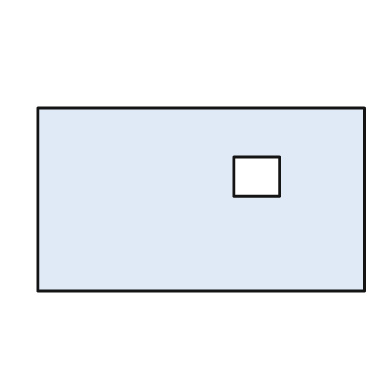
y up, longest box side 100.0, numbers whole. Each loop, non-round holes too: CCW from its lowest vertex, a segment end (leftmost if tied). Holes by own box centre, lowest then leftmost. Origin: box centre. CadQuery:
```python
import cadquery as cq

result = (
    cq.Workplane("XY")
    .moveTo(-50.0, -28.0)
    .lineTo(50.0, -28.0)
    .lineTo(50.0, 28.0)
    .lineTo(-50.0, 28.0)
    .close()
    .moveTo(10.0, 1.0)
    .lineTo(24.0, 1.0)
    .lineTo(24.0, 13.0)
    .lineTo(10.0, 13.0)
    .close()
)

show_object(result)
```